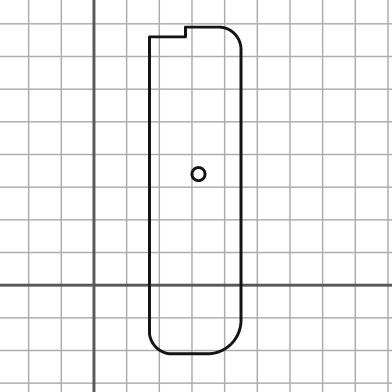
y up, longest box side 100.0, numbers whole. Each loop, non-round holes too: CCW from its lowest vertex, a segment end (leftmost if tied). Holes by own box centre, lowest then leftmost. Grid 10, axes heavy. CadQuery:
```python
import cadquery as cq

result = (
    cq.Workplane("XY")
    .moveTo(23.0, -21.0)
    .lineTo(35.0, -21.0)
    .threePointArc((42.0, -18.0), (45.0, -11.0))
    .lineTo(45.0, 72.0)
    .threePointArc((43.0, 77.0), (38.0, 79.0))
    .lineTo(28.0, 79.0)
    .lineTo(28.0, 76.0)
    .lineTo(17.0, 76.0)
    .lineTo(17.0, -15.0)
    .threePointArc((19.0, -19.0), (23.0, -21.0))
    .close()
    .moveTo(32.0, 34.0)
    .circle(2.0)
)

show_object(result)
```